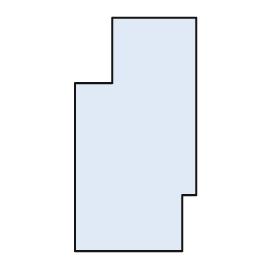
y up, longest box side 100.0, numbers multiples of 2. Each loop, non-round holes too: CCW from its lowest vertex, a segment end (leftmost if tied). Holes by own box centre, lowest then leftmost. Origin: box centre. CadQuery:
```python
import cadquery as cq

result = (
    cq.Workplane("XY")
    .moveTo(-26.0, -50.0)
    .lineTo(20.0, -50.0)
    .lineTo(20.0, -26.0)
    .lineTo(26.0, -26.0)
    .lineTo(26.0, 50.0)
    .lineTo(-10.0, 50.0)
    .lineTo(-10.0, 22.0)
    .lineTo(-26.0, 22.0)
    .close()
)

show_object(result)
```